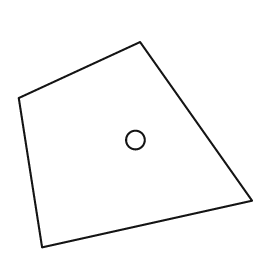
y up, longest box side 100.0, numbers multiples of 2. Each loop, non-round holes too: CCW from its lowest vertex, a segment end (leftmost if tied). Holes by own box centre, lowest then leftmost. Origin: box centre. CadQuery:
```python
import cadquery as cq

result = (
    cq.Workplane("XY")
    .moveTo(-40.0, -44.0)
    .lineTo(50.0, -24.0)
    .lineTo(2.0, 44.0)
    .lineTo(-50.0, 20.0)
    .close()
    .moveTo(0.0, 2.0)
    .circle(4.0)
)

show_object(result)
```